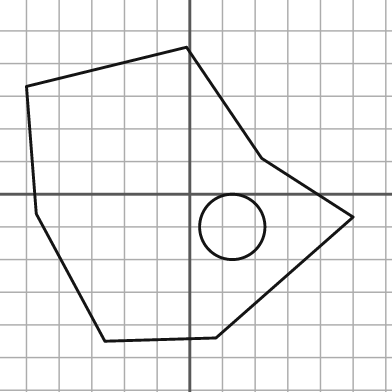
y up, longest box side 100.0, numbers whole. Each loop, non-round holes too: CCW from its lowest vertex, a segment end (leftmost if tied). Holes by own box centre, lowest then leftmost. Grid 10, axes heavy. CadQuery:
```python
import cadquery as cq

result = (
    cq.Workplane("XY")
    .moveTo(-26.0, -45.0)
    .lineTo(8.0, -44.0)
    .lineTo(50.0, -7.0)
    .lineTo(22.0, 11.0)
    .lineTo(-1.0, 45.0)
    .lineTo(-50.0, 33.0)
    .lineTo(-47.0, -6.0)
    .close()
    .moveTo(13.0, -10.0)
    .circle(10.0)
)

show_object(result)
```